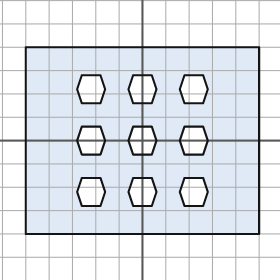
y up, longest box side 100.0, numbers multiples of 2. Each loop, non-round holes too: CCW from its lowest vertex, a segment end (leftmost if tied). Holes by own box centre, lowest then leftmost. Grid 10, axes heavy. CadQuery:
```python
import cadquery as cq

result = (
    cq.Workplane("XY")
    .moveTo(-50.0, -40.0)
    .lineTo(50.0, -40.0)
    .lineTo(50.0, 40.0)
    .lineTo(-50.0, 40.0)
    .close()
    .moveTo(-26.0, -28.0)
    .lineTo(-18.0, -28.0)
    .lineTo(-16.0, -22.0)
    .lineTo(-18.0, -16.0)
    .lineTo(-26.0, -16.0)
    .lineTo(-28.0, -22.0)
    .close()
    .moveTo(-4.0, -28.0)
    .lineTo(4.0, -28.0)
    .lineTo(6.0, -22.0)
    .lineTo(4.0, -16.0)
    .lineTo(-4.0, -16.0)
    .lineTo(-6.0, -22.0)
    .close()
    .moveTo(18.0, -28.0)
    .lineTo(26.0, -28.0)
    .lineTo(28.0, -22.0)
    .lineTo(26.0, -16.0)
    .lineTo(18.0, -16.0)
    .lineTo(16.0, -22.0)
    .close()
    .moveTo(-26.0, -6.0)
    .lineTo(-18.0, -6.0)
    .lineTo(-16.0, 0.0)
    .lineTo(-18.0, 6.0)
    .lineTo(-26.0, 6.0)
    .lineTo(-28.0, 0.0)
    .close()
    .moveTo(-4.0, -6.0)
    .lineTo(4.0, -6.0)
    .lineTo(6.0, 0.0)
    .lineTo(4.0, 6.0)
    .lineTo(-4.0, 6.0)
    .lineTo(-6.0, 0.0)
    .close()
    .moveTo(18.0, -6.0)
    .lineTo(26.0, -6.0)
    .lineTo(28.0, 0.0)
    .lineTo(26.0, 6.0)
    .lineTo(18.0, 6.0)
    .lineTo(16.0, 0.0)
    .close()
    .moveTo(-26.0, 16.0)
    .lineTo(-18.0, 16.0)
    .lineTo(-16.0, 22.0)
    .lineTo(-18.0, 28.0)
    .lineTo(-26.0, 28.0)
    .lineTo(-28.0, 22.0)
    .close()
    .moveTo(-4.0, 16.0)
    .lineTo(4.0, 16.0)
    .lineTo(6.0, 22.0)
    .lineTo(4.0, 28.0)
    .lineTo(-4.0, 28.0)
    .lineTo(-6.0, 22.0)
    .close()
    .moveTo(18.0, 16.0)
    .lineTo(26.0, 16.0)
    .lineTo(28.0, 22.0)
    .lineTo(26.0, 28.0)
    .lineTo(18.0, 28.0)
    .lineTo(16.0, 22.0)
    .close()
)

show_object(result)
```